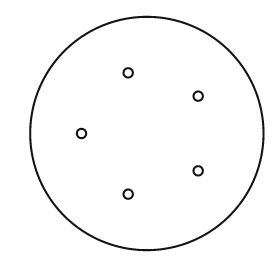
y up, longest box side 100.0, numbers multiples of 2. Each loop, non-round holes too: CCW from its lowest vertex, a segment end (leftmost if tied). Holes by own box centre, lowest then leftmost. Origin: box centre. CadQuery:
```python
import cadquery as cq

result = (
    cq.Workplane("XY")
    .moveTo(0.0, 0.0)
    .circle(50.0)
    .moveTo(-8.0, -26.0)
    .circle(2.0)
    .moveTo(22.0, -16.0)
    .circle(2.0)
    .moveTo(-28.0, 0.0)
    .circle(2.0)
    .moveTo(22.0, 16.0)
    .circle(2.0)
    .moveTo(-8.0, 26.0)
    .circle(2.0)
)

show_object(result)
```